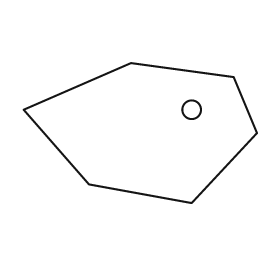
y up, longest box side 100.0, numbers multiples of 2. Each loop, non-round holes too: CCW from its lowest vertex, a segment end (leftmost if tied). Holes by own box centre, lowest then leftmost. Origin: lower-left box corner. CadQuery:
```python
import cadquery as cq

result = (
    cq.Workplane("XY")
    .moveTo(72.0, 0.0)
    .lineTo(100.0, 30.0)
    .lineTo(90.0, 54.0)
    .lineTo(46.0, 60.0)
    .lineTo(0.0, 40.0)
    .lineTo(28.0, 8.0)
    .close()
    .moveTo(72.0, 40.0)
    .circle(4.0)
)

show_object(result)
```